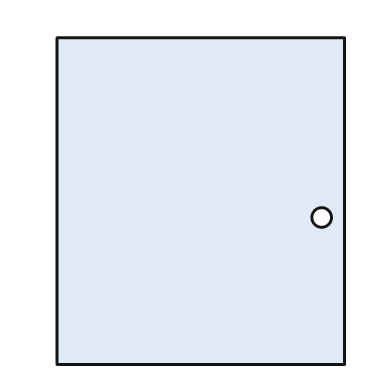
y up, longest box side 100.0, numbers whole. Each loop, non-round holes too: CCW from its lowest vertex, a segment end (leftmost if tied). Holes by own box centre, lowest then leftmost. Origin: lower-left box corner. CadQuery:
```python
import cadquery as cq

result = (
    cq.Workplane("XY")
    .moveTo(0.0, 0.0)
    .lineTo(88.0, 0.0)
    .lineTo(88.0, 100.0)
    .lineTo(0.0, 100.0)
    .close()
    .moveTo(81.0, 45.0)
    .circle(3.0)
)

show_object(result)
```